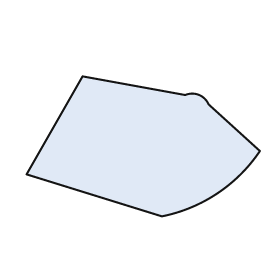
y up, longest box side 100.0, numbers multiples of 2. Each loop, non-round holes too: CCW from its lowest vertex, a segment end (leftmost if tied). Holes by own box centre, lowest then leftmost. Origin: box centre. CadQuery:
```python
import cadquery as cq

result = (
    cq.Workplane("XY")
    .moveTo(8.0, -30.0)
    .threePointArc((32.0, -20.0), (50.0, -2.0))
    .lineTo(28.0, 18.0)
    .threePointArc((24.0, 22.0), (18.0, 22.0))
    .lineTo(-26.0, 30.0)
    .lineTo(-50.0, -12.0)
    .close()
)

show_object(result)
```